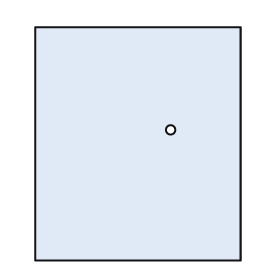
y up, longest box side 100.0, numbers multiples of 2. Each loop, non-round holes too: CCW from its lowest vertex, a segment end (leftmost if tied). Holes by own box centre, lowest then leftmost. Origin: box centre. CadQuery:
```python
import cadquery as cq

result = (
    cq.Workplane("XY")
    .moveTo(-44.0, -50.0)
    .lineTo(44.0, -50.0)
    .lineTo(44.0, 50.0)
    .lineTo(-44.0, 50.0)
    .close()
    .moveTo(14.0, 6.0)
    .circle(2.0)
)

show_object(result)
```